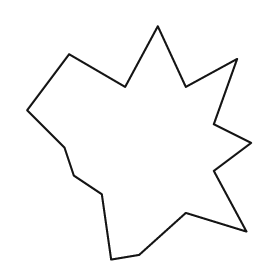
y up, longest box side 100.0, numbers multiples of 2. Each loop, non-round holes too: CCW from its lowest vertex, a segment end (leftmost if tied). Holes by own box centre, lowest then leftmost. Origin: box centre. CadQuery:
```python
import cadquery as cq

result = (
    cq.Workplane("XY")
    .moveTo(-12.0, -50.0)
    .lineTo(0.0, -48.0)
    .lineTo(20.0, -30.0)
    .lineTo(46.0, -38.0)
    .lineTo(32.0, -12.0)
    .lineTo(48.0, 0.0)
    .lineTo(32.0, 8.0)
    .lineTo(42.0, 36.0)
    .lineTo(20.0, 24.0)
    .lineTo(8.0, 50.0)
    .lineTo(-6.0, 24.0)
    .lineTo(-30.0, 38.0)
    .lineTo(-48.0, 14.0)
    .lineTo(-32.0, -2.0)
    .lineTo(-28.0, -14.0)
    .lineTo(-16.0, -22.0)
    .close()
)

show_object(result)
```